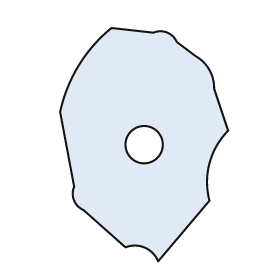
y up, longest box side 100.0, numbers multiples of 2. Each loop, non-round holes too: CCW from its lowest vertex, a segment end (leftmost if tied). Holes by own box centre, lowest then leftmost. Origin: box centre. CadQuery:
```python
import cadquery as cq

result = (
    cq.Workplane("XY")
    .moveTo(6.0, -50.0)
    .lineTo(28.0, -24.0)
    .threePointArc((28.0, -8.0), (36.0, 6.0))
    .lineTo(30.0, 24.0)
    .threePointArc((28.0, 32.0), (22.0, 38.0))
    .lineTo(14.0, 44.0)
    .threePointArc((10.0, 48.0), (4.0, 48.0))
    .lineTo(-14.0, 50.0)
    .threePointArc((-28.0, 34.0), (-36.0, 14.0))
    .lineTo(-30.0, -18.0)
    .threePointArc((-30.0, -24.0), (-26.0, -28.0))
    .lineTo(-8.0, -44.0)
    .threePointArc((0.0, -44.0), (6.0, -50.0))
    .close()
    .moveTo(0.0, 0.0)
    .circle(8.0)
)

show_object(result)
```